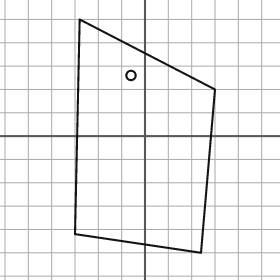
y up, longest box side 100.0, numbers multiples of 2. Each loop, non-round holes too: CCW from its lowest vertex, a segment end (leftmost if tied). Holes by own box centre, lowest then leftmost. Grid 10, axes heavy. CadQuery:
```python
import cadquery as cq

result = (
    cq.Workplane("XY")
    .moveTo(24.0, -50.0)
    .lineTo(30.0, 20.0)
    .lineTo(-28.0, 50.0)
    .lineTo(-30.0, -42.0)
    .close()
    .moveTo(-6.0, 26.0)
    .circle(2.0)
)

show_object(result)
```